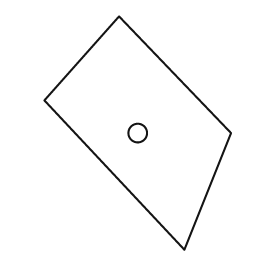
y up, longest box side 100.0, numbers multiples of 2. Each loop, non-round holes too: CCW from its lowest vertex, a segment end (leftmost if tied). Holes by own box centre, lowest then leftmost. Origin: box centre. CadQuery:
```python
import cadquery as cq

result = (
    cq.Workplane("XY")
    .moveTo(20.0, -50.0)
    .lineTo(40.0, 0.0)
    .lineTo(-8.0, 50.0)
    .lineTo(-40.0, 14.0)
    .close()
    .moveTo(0.0, 0.0)
    .circle(4.0)
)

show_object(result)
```